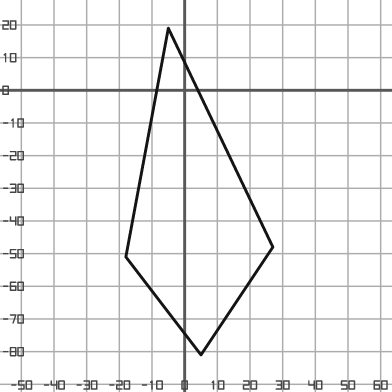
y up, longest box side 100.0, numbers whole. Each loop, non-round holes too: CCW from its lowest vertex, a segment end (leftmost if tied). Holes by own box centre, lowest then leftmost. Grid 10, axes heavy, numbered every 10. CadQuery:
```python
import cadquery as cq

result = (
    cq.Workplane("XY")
    .moveTo(5.0, -81.0)
    .lineTo(27.0, -48.0)
    .lineTo(-5.0, 19.0)
    .lineTo(-18.0, -51.0)
    .close()
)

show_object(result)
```